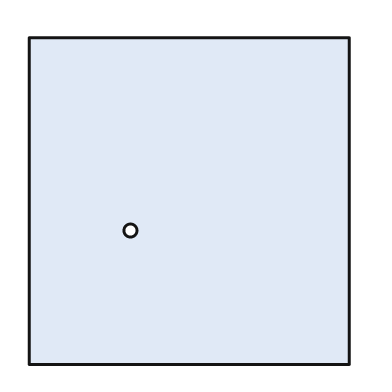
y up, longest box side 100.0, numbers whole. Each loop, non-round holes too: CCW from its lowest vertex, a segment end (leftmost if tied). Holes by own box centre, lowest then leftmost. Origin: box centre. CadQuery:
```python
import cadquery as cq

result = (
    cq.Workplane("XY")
    .moveTo(-49.0, -50.0)
    .lineTo(49.0, -50.0)
    .lineTo(49.0, 50.0)
    .lineTo(-49.0, 50.0)
    .close()
    .moveTo(-18.0, -9.0)
    .circle(2.0)
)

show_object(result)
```